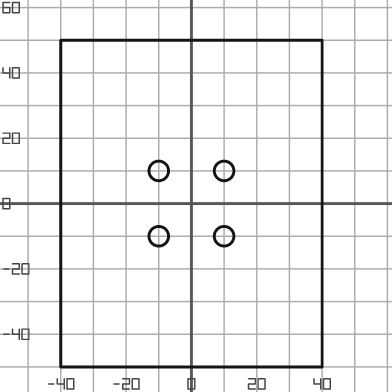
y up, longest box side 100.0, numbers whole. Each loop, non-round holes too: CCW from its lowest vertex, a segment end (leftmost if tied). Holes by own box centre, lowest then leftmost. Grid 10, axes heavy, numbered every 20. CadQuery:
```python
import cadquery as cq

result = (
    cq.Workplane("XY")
    .moveTo(-40.0, -50.0)
    .lineTo(40.0, -50.0)
    .lineTo(40.0, 50.0)
    .lineTo(-40.0, 50.0)
    .close()
    .moveTo(-10.0, -10.0)
    .circle(3.0)
    .moveTo(10.0, -10.0)
    .circle(3.0)
    .moveTo(-10.0, 10.0)
    .circle(3.0)
    .moveTo(10.0, 10.0)
    .circle(3.0)
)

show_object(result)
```